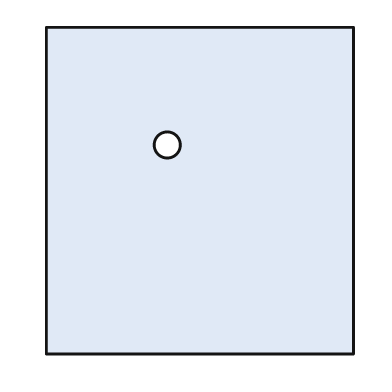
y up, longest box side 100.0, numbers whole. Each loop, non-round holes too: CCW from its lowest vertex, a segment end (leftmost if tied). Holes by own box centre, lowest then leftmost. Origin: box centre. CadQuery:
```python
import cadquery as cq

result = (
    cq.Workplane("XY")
    .moveTo(-47.0, -50.0)
    .lineTo(47.0, -50.0)
    .lineTo(47.0, 50.0)
    .lineTo(-47.0, 50.0)
    .close()
    .moveTo(-10.0, 14.0)
    .circle(4.0)
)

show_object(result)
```